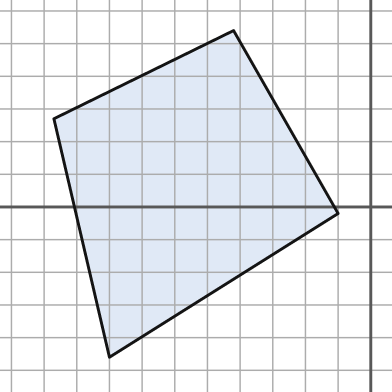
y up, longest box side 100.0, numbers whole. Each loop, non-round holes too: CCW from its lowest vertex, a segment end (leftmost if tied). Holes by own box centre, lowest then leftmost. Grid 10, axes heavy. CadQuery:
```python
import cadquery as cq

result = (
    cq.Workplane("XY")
    .moveTo(-80.0, -46.0)
    .lineTo(-10.0, -2.0)
    .lineTo(-42.0, 54.0)
    .lineTo(-97.0, 27.0)
    .close()
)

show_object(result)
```